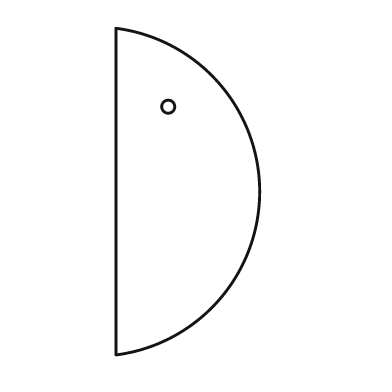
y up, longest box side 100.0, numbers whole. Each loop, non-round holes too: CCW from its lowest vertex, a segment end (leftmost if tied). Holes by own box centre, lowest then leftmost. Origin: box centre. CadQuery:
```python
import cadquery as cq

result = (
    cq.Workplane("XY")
    .moveTo(-22.0, -50.0)
    .threePointArc((22.0, 0.0), (-22.0, 50.0))
    .close()
    .moveTo(-6.0, 26.0)
    .circle(2.0)
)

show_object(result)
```